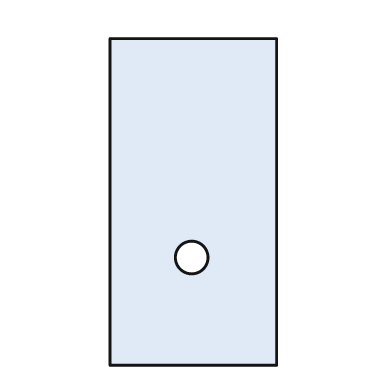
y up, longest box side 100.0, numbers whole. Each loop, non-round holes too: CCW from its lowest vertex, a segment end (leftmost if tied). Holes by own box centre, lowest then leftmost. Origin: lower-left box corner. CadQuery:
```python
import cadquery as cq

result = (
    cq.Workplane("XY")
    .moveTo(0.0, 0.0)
    .lineTo(51.0, 0.0)
    .lineTo(51.0, 100.0)
    .lineTo(0.0, 100.0)
    .close()
    .moveTo(25.0, 33.0)
    .circle(5.0)
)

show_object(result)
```